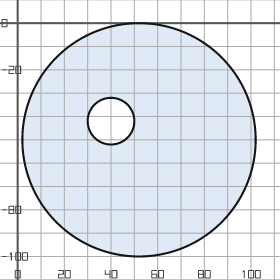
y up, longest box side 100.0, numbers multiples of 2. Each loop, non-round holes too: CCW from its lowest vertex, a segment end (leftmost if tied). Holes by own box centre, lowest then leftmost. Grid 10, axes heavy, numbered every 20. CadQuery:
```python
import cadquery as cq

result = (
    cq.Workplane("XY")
    .moveTo(52.0, -50.0)
    .circle(50.0)
    .moveTo(40.0, -42.0)
    .circle(10.0)
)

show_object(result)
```